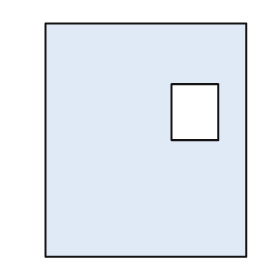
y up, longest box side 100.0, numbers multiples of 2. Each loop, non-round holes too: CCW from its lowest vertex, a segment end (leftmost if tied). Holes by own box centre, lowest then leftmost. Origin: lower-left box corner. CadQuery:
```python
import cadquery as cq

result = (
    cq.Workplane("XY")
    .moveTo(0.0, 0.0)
    .lineTo(86.0, 0.0)
    .lineTo(86.0, 100.0)
    .lineTo(0.0, 100.0)
    .close()
    .moveTo(54.0, 50.0)
    .lineTo(74.0, 50.0)
    .lineTo(74.0, 74.0)
    .lineTo(54.0, 74.0)
    .close()
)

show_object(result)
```